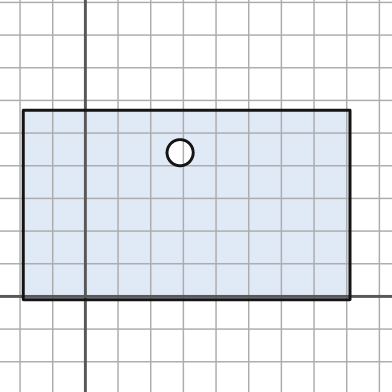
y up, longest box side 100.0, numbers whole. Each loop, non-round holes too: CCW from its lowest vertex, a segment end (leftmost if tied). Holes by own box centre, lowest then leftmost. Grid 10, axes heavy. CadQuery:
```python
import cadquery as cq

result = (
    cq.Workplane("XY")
    .moveTo(-19.0, -1.0)
    .lineTo(81.0, -1.0)
    .lineTo(81.0, 57.0)
    .lineTo(-19.0, 57.0)
    .close()
    .moveTo(29.0, 44.0)
    .circle(4.0)
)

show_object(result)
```